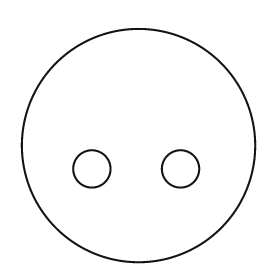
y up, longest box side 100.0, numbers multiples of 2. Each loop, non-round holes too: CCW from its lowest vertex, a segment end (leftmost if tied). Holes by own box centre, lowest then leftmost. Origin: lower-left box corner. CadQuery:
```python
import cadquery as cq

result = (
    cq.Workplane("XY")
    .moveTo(50.0, 50.0)
    .circle(50.0)
    .moveTo(30.0, 40.0)
    .circle(8.0)
    .moveTo(68.0, 40.0)
    .circle(8.0)
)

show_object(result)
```